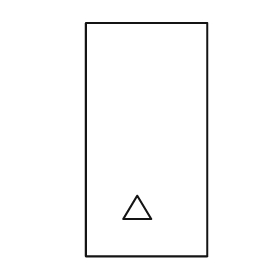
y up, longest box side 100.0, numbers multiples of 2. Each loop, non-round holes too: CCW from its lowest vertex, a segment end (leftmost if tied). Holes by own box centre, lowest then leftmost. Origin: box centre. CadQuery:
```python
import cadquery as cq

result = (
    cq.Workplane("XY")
    .moveTo(-26.0, -50.0)
    .lineTo(26.0, -50.0)
    .lineTo(26.0, 50.0)
    .lineTo(-26.0, 50.0)
    .close()
    .moveTo(-10.0, -34.0)
    .lineTo(2.0, -34.0)
    .lineTo(-4.0, -24.0)
    .close()
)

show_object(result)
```